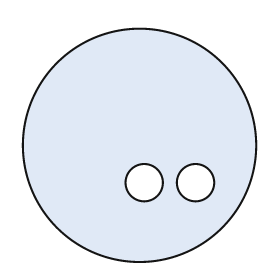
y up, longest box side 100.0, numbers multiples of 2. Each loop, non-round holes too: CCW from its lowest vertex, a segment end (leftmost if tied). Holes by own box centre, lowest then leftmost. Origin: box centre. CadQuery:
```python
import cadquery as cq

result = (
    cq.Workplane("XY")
    .moveTo(0.0, 0.0)
    .circle(50.0)
    .moveTo(2.0, -16.0)
    .circle(8.0)
    .moveTo(24.0, -16.0)
    .circle(8.0)
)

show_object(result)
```